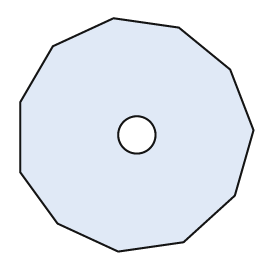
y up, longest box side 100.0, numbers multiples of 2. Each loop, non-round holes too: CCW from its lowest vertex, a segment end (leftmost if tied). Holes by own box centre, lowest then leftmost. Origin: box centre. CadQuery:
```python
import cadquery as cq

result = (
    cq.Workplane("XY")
    .moveTo(-8.0, -50.0)
    .lineTo(20.0, -46.0)
    .lineTo(42.0, -26.0)
    .lineTo(50.0, 2.0)
    .lineTo(40.0, 28.0)
    .lineTo(18.0, 46.0)
    .lineTo(-10.0, 50.0)
    .lineTo(-36.0, 38.0)
    .lineTo(-50.0, 14.0)
    .lineTo(-50.0, -16.0)
    .lineTo(-34.0, -38.0)
    .close()
    .moveTo(0.0, 0.0)
    .circle(8.0)
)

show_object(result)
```